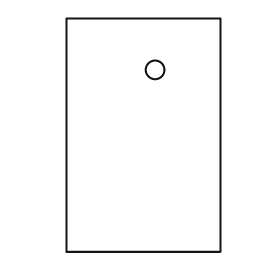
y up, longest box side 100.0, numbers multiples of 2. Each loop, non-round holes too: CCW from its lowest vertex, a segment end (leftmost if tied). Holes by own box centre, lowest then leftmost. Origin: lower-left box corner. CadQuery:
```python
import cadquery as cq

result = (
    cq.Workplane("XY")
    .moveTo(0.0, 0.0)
    .lineTo(66.0, 0.0)
    .lineTo(66.0, 100.0)
    .lineTo(0.0, 100.0)
    .close()
    .moveTo(38.0, 78.0)
    .circle(4.0)
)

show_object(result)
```